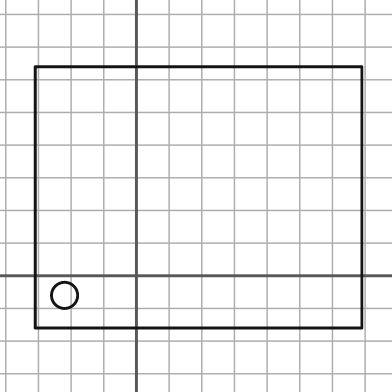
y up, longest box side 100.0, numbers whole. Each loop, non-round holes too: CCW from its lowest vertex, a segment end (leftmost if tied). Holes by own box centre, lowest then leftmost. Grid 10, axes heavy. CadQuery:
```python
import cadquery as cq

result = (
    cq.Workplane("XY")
    .moveTo(-31.0, -16.0)
    .lineTo(69.0, -16.0)
    .lineTo(69.0, 64.0)
    .lineTo(-31.0, 64.0)
    .close()
    .moveTo(-22.0, -6.0)
    .circle(4.0)
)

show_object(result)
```